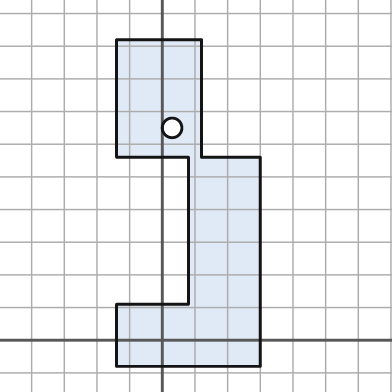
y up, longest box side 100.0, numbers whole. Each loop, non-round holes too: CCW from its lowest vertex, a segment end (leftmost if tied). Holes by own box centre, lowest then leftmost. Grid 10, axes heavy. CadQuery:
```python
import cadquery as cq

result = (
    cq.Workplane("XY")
    .moveTo(-14.0, -8.0)
    .lineTo(30.0, -8.0)
    .lineTo(30.0, 56.0)
    .lineTo(12.0, 56.0)
    .lineTo(12.0, 92.0)
    .lineTo(-14.0, 92.0)
    .lineTo(-14.0, 56.0)
    .lineTo(8.0, 56.0)
    .lineTo(8.0, 11.0)
    .lineTo(-14.0, 11.0)
    .close()
    .moveTo(3.0, 65.0)
    .circle(3.0)
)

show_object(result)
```